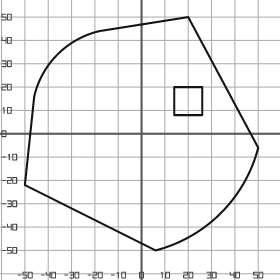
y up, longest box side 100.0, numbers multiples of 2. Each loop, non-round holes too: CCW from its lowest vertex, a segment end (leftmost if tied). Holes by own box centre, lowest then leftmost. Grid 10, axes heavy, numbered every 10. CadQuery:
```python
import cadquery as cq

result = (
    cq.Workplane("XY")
    .moveTo(6.0, -50.0)
    .threePointArc((34.0, -34.0), (50.0, -6.0))
    .lineTo(20.0, 50.0)
    .lineTo(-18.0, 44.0)
    .threePointArc((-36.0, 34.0), (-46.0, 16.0))
    .lineTo(-50.0, -22.0)
    .close()
    .moveTo(14.0, 8.0)
    .lineTo(26.0, 8.0)
    .lineTo(26.0, 20.0)
    .lineTo(14.0, 20.0)
    .close()
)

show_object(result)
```